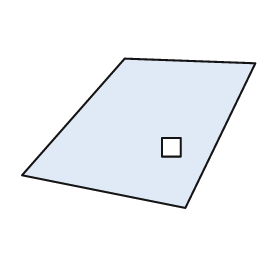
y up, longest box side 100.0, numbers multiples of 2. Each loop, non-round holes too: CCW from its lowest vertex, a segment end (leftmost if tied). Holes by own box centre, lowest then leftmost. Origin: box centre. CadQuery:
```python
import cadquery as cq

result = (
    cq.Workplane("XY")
    .moveTo(20.0, -32.0)
    .lineTo(50.0, 30.0)
    .lineTo(-6.0, 32.0)
    .lineTo(-50.0, -18.0)
    .close()
    .moveTo(10.0, -10.0)
    .lineTo(18.0, -10.0)
    .lineTo(18.0, -2.0)
    .lineTo(10.0, -2.0)
    .close()
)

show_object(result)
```